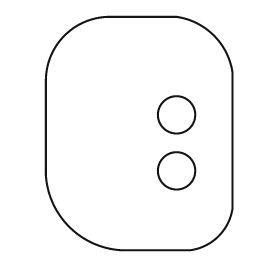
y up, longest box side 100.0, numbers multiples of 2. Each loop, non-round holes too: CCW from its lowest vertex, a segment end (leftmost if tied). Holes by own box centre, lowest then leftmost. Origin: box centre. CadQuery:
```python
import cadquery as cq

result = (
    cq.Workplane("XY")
    .moveTo(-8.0, -50.0)
    .lineTo(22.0, -50.0)
    .threePointArc((34.0, -44.0), (40.0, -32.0))
    .lineTo(40.0, 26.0)
    .threePointArc((32.0, 42.0), (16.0, 50.0))
    .lineTo(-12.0, 50.0)
    .threePointArc((-32.0, 42.0), (-40.0, 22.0))
    .lineTo(-40.0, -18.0)
    .threePointArc((-30.0, -40.0), (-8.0, -50.0))
    .close()
    .moveTo(16.0, -16.0)
    .circle(8.0)
    .moveTo(16.0, 8.0)
    .circle(8.0)
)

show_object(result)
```